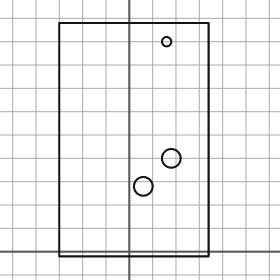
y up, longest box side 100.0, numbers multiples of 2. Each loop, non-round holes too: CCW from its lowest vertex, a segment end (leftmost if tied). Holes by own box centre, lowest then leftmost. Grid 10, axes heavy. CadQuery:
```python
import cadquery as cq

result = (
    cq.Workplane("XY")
    .moveTo(-30.0, -2.0)
    .lineTo(34.0, -2.0)
    .lineTo(34.0, 98.0)
    .lineTo(-30.0, 98.0)
    .close()
    .moveTo(6.0, 28.0)
    .circle(4.0)
    .moveTo(18.0, 40.0)
    .circle(4.0)
    .moveTo(16.0, 90.0)
    .circle(2.0)
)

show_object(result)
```